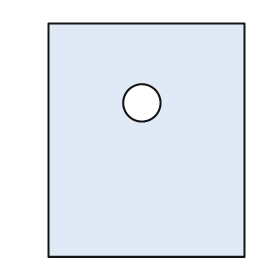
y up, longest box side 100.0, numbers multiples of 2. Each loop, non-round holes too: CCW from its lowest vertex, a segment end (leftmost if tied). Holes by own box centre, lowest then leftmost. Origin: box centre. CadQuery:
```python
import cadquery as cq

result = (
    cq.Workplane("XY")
    .moveTo(-42.0, -50.0)
    .lineTo(42.0, -50.0)
    .lineTo(42.0, 50.0)
    .lineTo(-42.0, 50.0)
    .close()
    .moveTo(-2.0, 16.0)
    .circle(8.0)
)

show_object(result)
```